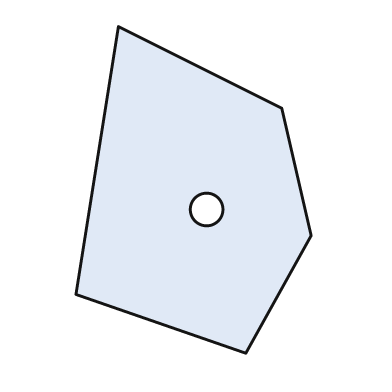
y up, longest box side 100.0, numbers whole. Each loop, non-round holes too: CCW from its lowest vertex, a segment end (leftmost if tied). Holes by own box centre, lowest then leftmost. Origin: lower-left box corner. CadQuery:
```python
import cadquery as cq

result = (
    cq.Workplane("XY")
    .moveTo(52.0, 0.0)
    .lineTo(72.0, 36.0)
    .lineTo(63.0, 75.0)
    .lineTo(13.0, 100.0)
    .lineTo(0.0, 18.0)
    .close()
    .moveTo(40.0, 44.0)
    .circle(5.0)
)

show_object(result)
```